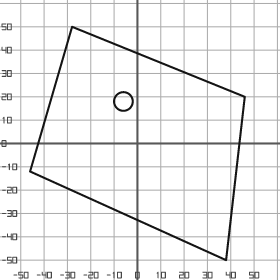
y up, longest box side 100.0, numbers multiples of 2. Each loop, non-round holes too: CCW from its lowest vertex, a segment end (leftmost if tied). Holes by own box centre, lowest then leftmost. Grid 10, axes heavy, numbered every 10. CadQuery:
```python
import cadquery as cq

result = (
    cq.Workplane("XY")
    .moveTo(38.0, -50.0)
    .lineTo(46.0, 20.0)
    .lineTo(-28.0, 50.0)
    .lineTo(-46.0, -12.0)
    .close()
    .moveTo(-6.0, 18.0)
    .circle(4.0)
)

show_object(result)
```